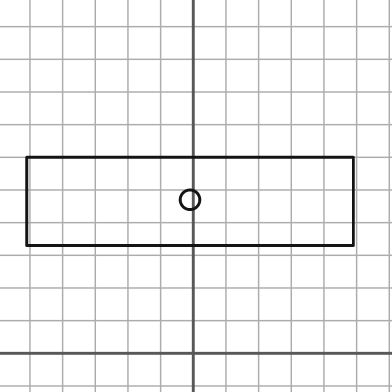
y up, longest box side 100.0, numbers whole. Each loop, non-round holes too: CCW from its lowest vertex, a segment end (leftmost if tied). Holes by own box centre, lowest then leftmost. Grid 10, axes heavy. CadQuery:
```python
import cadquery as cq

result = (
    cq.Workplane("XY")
    .moveTo(-51.0, 33.0)
    .lineTo(49.0, 33.0)
    .lineTo(49.0, 60.0)
    .lineTo(-51.0, 60.0)
    .close()
    .moveTo(-1.0, 47.0)
    .circle(3.0)
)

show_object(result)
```